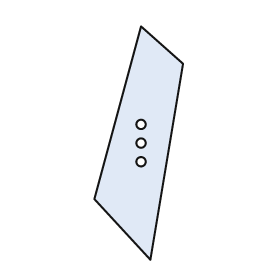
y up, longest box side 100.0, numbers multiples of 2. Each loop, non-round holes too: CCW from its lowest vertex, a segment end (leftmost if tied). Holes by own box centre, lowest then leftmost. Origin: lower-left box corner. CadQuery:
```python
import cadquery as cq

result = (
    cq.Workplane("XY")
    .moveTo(24.0, 0.0)
    .lineTo(38.0, 84.0)
    .lineTo(20.0, 100.0)
    .lineTo(0.0, 26.0)
    .close()
    .moveTo(20.0, 42.0)
    .circle(2.0)
    .moveTo(20.0, 50.0)
    .circle(2.0)
    .moveTo(20.0, 58.0)
    .circle(2.0)
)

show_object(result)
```